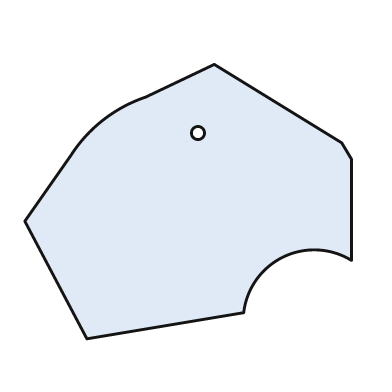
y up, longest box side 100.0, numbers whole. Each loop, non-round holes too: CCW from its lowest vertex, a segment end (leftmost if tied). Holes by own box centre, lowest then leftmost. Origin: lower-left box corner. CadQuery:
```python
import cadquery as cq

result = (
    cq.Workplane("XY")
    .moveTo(19.0, 0.0)
    .lineTo(67.0, 8.0)
    .threePointArc((79.0, 25.0), (100.0, 24.0))
    .lineTo(100.0, 55.0)
    .lineTo(97.0, 60.0)
    .lineTo(58.0, 84.0)
    .lineTo(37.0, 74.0)
    .threePointArc((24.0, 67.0), (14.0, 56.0))
    .lineTo(0.0, 36.0)
    .close()
    .moveTo(53.0, 63.0)
    .circle(2.0)
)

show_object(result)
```